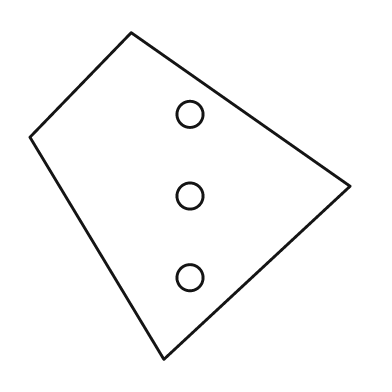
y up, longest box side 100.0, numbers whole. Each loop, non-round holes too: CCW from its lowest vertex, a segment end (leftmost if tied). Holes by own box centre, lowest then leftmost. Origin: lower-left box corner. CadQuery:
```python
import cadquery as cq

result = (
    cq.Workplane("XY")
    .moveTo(41.0, 0.0)
    .lineTo(98.0, 53.0)
    .lineTo(31.0, 100.0)
    .lineTo(0.0, 68.0)
    .close()
    .moveTo(49.0, 25.0)
    .circle(4.0)
    .moveTo(49.0, 50.0)
    .circle(4.0)
    .moveTo(49.0, 75.0)
    .circle(4.0)
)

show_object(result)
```